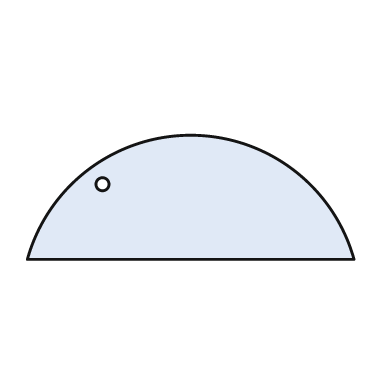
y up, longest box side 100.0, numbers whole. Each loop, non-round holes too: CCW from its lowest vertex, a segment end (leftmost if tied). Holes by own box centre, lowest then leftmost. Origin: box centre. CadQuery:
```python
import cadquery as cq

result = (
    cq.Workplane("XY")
    .moveTo(-50.0, -19.0)
    .lineTo(50.0, -19.0)
    .threePointArc((0.0, 19.0), (-50.0, -19.0))
    .close()
    .moveTo(-27.0, 4.0)
    .circle(2.0)
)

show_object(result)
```